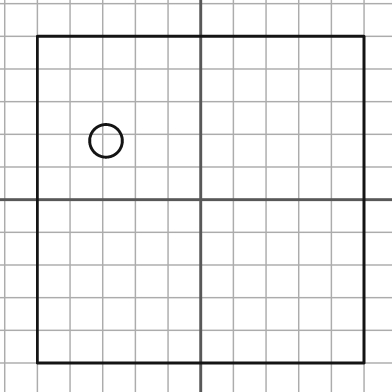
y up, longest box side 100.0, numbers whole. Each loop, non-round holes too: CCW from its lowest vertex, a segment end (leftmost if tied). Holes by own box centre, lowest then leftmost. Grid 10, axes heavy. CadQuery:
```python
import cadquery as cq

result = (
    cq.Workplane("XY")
    .moveTo(-50.0, -50.0)
    .lineTo(50.0, -50.0)
    .lineTo(50.0, 50.0)
    .lineTo(-50.0, 50.0)
    .close()
    .moveTo(-29.0, 18.0)
    .circle(5.0)
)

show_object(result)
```